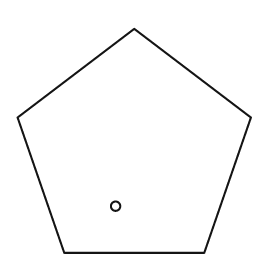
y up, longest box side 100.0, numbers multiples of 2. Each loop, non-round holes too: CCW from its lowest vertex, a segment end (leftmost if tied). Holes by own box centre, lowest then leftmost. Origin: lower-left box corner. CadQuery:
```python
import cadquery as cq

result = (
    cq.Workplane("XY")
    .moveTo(20.0, 0.0)
    .lineTo(80.0, 0.0)
    .lineTo(100.0, 58.0)
    .lineTo(50.0, 96.0)
    .lineTo(0.0, 58.0)
    .close()
    .moveTo(42.0, 20.0)
    .circle(2.0)
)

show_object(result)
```